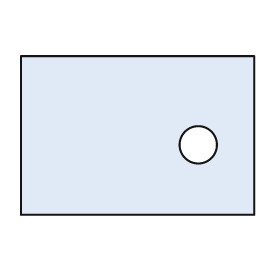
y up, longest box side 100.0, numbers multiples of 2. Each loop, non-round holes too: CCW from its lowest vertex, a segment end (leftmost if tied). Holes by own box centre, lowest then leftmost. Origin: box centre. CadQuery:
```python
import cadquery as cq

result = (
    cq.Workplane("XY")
    .moveTo(-50.0, -34.0)
    .lineTo(50.0, -34.0)
    .lineTo(50.0, 34.0)
    .lineTo(-50.0, 34.0)
    .close()
    .moveTo(26.0, -4.0)
    .circle(8.0)
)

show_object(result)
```